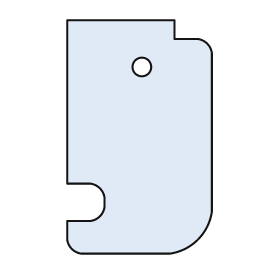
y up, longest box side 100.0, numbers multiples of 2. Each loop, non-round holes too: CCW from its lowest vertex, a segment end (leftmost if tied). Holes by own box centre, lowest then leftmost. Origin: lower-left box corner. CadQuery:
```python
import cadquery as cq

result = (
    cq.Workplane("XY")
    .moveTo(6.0, 0.0)
    .lineTo(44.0, 0.0)
    .threePointArc((56.0, 6.0), (62.0, 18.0))
    .lineTo(62.0, 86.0)
    .threePointArc((60.0, 90.0), (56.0, 92.0))
    .lineTo(46.0, 92.0)
    .lineTo(46.0, 100.0)
    .lineTo(0.0, 100.0)
    .lineTo(0.0, 30.0)
    .lineTo(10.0, 30.0)
    .threePointArc((14.0, 28.0), (16.0, 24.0))
    .lineTo(16.0, 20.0)
    .threePointArc((14.0, 16.0), (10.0, 14.0))
    .lineTo(0.0, 14.0)
    .lineTo(0.0, 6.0)
    .threePointArc((2.0, 2.0), (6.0, 0.0))
    .close()
    .moveTo(32.0, 80.0)
    .circle(4.0)
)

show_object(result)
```